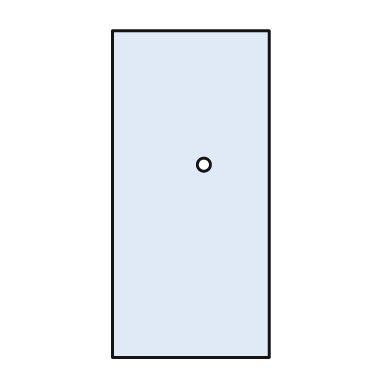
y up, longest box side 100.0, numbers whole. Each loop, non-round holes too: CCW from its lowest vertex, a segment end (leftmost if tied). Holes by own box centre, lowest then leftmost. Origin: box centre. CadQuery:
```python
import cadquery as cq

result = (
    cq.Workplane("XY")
    .moveTo(-24.0, -50.0)
    .lineTo(24.0, -50.0)
    .lineTo(24.0, 50.0)
    .lineTo(-24.0, 50.0)
    .close()
    .moveTo(4.0, 9.0)
    .circle(2.0)
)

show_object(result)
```